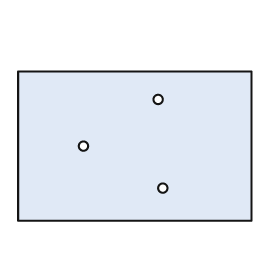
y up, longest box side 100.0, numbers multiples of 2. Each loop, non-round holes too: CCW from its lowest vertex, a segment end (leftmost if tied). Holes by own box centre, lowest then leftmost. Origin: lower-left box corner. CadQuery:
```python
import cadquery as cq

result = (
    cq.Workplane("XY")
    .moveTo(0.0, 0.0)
    .lineTo(100.0, 0.0)
    .lineTo(100.0, 64.0)
    .lineTo(0.0, 64.0)
    .close()
    .moveTo(62.0, 14.0)
    .circle(2.0)
    .moveTo(28.0, 32.0)
    .circle(2.0)
    .moveTo(60.0, 52.0)
    .circle(2.0)
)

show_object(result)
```